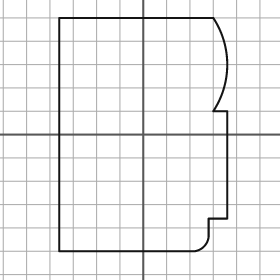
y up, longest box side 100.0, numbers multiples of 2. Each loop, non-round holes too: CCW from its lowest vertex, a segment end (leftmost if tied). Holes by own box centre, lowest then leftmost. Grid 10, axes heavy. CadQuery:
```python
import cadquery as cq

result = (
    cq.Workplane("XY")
    .moveTo(-36.0, -50.0)
    .lineTo(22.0, -50.0)
    .threePointArc((26.0, -48.0), (28.0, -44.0))
    .lineTo(28.0, -36.0)
    .lineTo(36.0, -36.0)
    .lineTo(36.0, 10.0)
    .lineTo(30.0, 10.0)
    .threePointArc((36.0, 30.0), (30.0, 50.0))
    .lineTo(-36.0, 50.0)
    .close()
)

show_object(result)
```